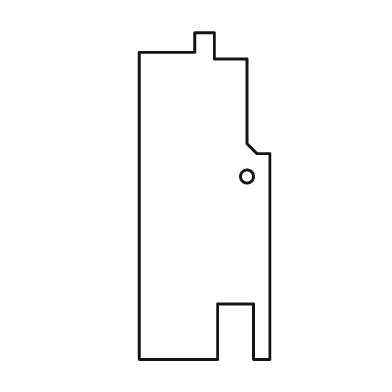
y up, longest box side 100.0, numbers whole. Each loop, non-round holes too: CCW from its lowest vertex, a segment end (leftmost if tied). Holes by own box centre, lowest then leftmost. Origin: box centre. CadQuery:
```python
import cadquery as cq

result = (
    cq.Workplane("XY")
    .moveTo(-20.0, -50.0)
    .lineTo(4.0, -50.0)
    .lineTo(4.0, -33.0)
    .lineTo(15.0, -33.0)
    .lineTo(15.0, -50.0)
    .lineTo(20.0, -50.0)
    .lineTo(20.0, 13.0)
    .lineTo(16.0, 13.0)
    .lineTo(13.0, 16.0)
    .lineTo(13.0, 42.0)
    .lineTo(3.0, 42.0)
    .lineTo(3.0, 50.0)
    .lineTo(-3.0, 50.0)
    .lineTo(-3.0, 44.0)
    .lineTo(-20.0, 44.0)
    .close()
    .moveTo(13.0, 6.0)
    .circle(2.0)
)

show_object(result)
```